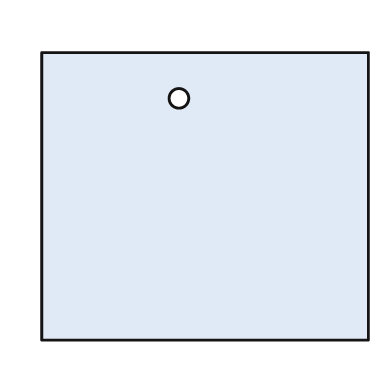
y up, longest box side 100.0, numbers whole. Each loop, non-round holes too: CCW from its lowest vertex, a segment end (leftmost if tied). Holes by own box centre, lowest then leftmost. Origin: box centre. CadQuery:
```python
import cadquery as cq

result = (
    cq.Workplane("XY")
    .moveTo(-50.0, -44.0)
    .lineTo(50.0, -44.0)
    .lineTo(50.0, 44.0)
    .lineTo(-50.0, 44.0)
    .close()
    .moveTo(-8.0, 30.0)
    .circle(3.0)
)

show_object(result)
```